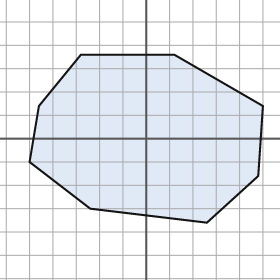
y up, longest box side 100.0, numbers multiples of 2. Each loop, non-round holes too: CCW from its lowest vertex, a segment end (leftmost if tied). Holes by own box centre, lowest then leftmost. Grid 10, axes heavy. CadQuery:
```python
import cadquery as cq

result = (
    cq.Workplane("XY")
    .moveTo(26.0, -36.0)
    .lineTo(48.0, -16.0)
    .lineTo(50.0, 14.0)
    .lineTo(12.0, 36.0)
    .lineTo(-28.0, 36.0)
    .lineTo(-46.0, 14.0)
    .lineTo(-50.0, -10.0)
    .lineTo(-24.0, -30.0)
    .close()
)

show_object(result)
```